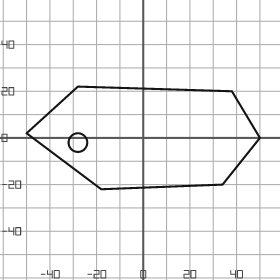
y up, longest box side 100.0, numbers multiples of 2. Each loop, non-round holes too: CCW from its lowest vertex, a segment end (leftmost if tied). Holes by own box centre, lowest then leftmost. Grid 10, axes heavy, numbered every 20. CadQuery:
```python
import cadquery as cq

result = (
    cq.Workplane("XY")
    .moveTo(-18.0, -22.0)
    .lineTo(34.0, -20.0)
    .lineTo(50.0, 0.0)
    .lineTo(38.0, 20.0)
    .lineTo(-28.0, 22.0)
    .lineTo(-50.0, 2.0)
    .close()
    .moveTo(-28.0, -2.0)
    .circle(4.0)
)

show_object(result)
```